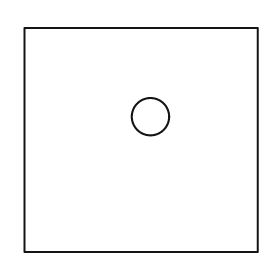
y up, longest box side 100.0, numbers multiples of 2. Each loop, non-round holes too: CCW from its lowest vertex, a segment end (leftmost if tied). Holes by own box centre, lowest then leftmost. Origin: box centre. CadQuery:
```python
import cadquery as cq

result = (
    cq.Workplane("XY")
    .moveTo(-50.0, -48.0)
    .lineTo(50.0, -48.0)
    .lineTo(50.0, 48.0)
    .lineTo(-50.0, 48.0)
    .close()
    .moveTo(4.0, 10.0)
    .circle(8.0)
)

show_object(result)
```